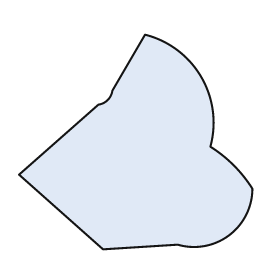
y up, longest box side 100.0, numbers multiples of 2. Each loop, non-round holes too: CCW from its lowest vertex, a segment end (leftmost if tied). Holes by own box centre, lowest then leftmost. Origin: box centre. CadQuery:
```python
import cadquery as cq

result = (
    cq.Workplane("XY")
    .moveTo(-14.0, -46.0)
    .lineTo(18.0, -44.0)
    .threePointArc((40.0, -40.0), (50.0, -20.0))
    .threePointArc((42.0, -10.0), (32.0, -2.0))
    .threePointArc((28.0, 28.0), (4.0, 46.0))
    .lineTo(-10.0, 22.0)
    .threePointArc((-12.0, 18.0), (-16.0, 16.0))
    .lineTo(-50.0, -14.0)
    .close()
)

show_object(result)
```